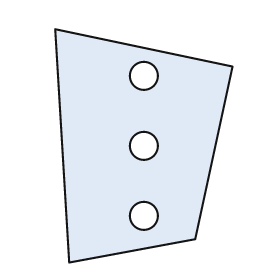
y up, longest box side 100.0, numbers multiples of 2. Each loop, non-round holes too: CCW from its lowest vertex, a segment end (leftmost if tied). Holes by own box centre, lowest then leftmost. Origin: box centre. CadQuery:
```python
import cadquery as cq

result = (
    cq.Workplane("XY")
    .moveTo(-32.0, -50.0)
    .lineTo(22.0, -40.0)
    .lineTo(38.0, 34.0)
    .lineTo(-38.0, 50.0)
    .close()
    .moveTo(0.0, -30.0)
    .circle(6.0)
    .moveTo(0.0, 0.0)
    .circle(6.0)
    .moveTo(0.0, 30.0)
    .circle(6.0)
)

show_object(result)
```